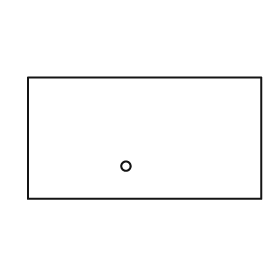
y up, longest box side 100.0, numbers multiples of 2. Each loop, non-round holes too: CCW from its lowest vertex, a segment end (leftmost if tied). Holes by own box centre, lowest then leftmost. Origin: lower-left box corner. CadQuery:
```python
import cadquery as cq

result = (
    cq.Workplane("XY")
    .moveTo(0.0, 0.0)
    .lineTo(100.0, 0.0)
    .lineTo(100.0, 52.0)
    .lineTo(0.0, 52.0)
    .close()
    .moveTo(42.0, 14.0)
    .circle(2.0)
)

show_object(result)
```